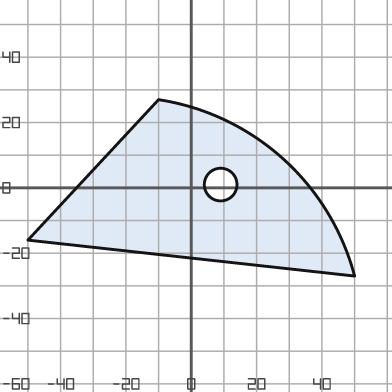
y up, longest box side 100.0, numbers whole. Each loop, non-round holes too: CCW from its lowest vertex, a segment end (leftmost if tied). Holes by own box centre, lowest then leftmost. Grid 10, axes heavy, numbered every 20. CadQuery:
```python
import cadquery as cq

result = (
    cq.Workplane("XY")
    .moveTo(50.0, -27.0)
    .threePointArc((28.0, 9.0), (-10.0, 27.0))
    .lineTo(-50.0, -16.0)
    .close()
    .moveTo(9.0, 1.0)
    .circle(5.0)
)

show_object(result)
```